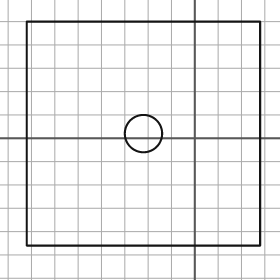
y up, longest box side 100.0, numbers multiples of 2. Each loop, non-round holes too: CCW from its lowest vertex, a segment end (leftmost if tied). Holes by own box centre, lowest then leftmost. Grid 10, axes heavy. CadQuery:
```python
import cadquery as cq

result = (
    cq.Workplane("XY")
    .moveTo(-72.0, -46.0)
    .lineTo(28.0, -46.0)
    .lineTo(28.0, 50.0)
    .lineTo(-72.0, 50.0)
    .close()
    .moveTo(-22.0, 2.0)
    .circle(8.0)
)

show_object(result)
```